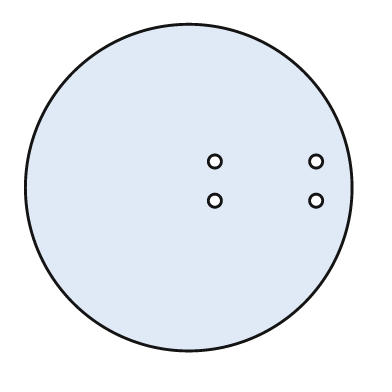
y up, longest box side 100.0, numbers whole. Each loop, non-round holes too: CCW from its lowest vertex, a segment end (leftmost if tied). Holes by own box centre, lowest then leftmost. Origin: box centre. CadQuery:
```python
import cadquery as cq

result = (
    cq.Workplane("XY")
    .moveTo(0.0, 0.0)
    .circle(50.0)
    .moveTo(8.0, -4.0)
    .circle(2.0)
    .moveTo(39.0, -4.0)
    .circle(2.0)
    .moveTo(8.0, 8.0)
    .circle(2.0)
    .moveTo(39.0, 8.0)
    .circle(2.0)
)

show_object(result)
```